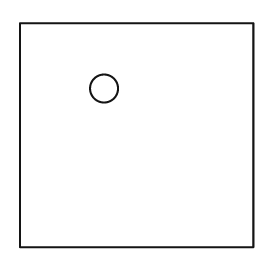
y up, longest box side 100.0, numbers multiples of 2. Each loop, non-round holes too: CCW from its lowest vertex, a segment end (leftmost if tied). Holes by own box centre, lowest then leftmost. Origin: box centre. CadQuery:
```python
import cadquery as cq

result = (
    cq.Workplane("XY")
    .moveTo(-50.0, -48.0)
    .lineTo(50.0, -48.0)
    .lineTo(50.0, 48.0)
    .lineTo(-50.0, 48.0)
    .close()
    .moveTo(-14.0, 20.0)
    .circle(6.0)
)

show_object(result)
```